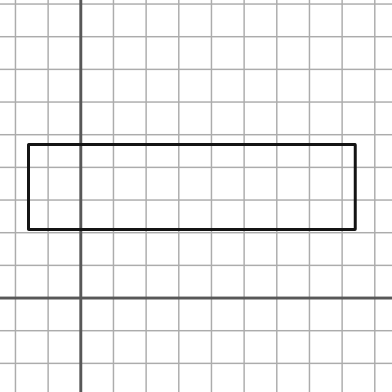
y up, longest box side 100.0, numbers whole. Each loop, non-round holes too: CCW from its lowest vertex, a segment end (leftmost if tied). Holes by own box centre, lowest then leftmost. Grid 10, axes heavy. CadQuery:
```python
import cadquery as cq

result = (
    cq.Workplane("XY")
    .moveTo(-16.0, 21.0)
    .lineTo(84.0, 21.0)
    .lineTo(84.0, 47.0)
    .lineTo(-16.0, 47.0)
    .close()
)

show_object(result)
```